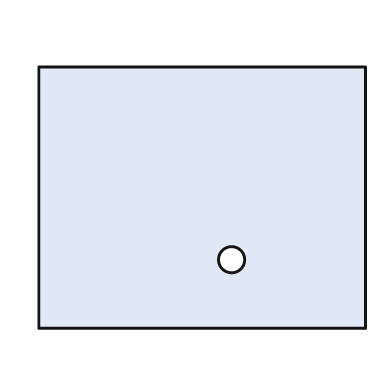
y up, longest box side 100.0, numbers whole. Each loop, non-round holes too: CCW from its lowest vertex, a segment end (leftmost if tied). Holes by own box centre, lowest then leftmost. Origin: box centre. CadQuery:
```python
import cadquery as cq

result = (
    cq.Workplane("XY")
    .moveTo(-50.0, -40.0)
    .lineTo(50.0, -40.0)
    .lineTo(50.0, 40.0)
    .lineTo(-50.0, 40.0)
    .close()
    .moveTo(9.0, -19.0)
    .circle(4.0)
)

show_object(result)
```